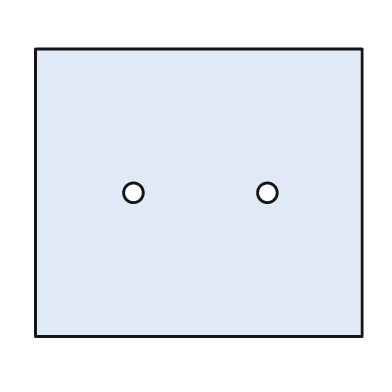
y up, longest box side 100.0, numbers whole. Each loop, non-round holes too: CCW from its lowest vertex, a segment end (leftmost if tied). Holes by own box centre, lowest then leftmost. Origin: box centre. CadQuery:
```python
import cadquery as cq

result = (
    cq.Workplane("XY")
    .moveTo(-50.0, -44.0)
    .lineTo(50.0, -44.0)
    .lineTo(50.0, 44.0)
    .lineTo(-50.0, 44.0)
    .close()
    .moveTo(-20.0, 0.0)
    .circle(3.0)
    .moveTo(21.0, 0.0)
    .circle(3.0)
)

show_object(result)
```